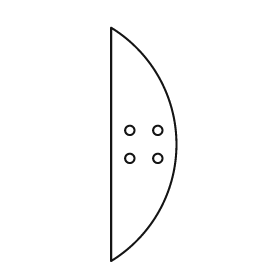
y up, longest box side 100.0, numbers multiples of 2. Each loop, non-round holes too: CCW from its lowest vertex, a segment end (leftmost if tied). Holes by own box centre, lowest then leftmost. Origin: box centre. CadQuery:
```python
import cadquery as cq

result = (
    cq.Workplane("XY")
    .moveTo(-14.0, -50.0)
    .threePointArc((14.0, 0.0), (-14.0, 50.0))
    .close()
    .moveTo(-6.0, -6.0)
    .circle(2.0)
    .moveTo(6.0, -6.0)
    .circle(2.0)
    .moveTo(-6.0, 6.0)
    .circle(2.0)
    .moveTo(6.0, 6.0)
    .circle(2.0)
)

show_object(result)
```